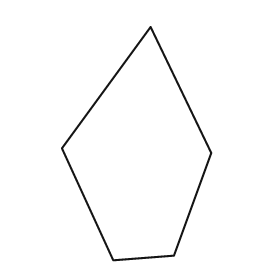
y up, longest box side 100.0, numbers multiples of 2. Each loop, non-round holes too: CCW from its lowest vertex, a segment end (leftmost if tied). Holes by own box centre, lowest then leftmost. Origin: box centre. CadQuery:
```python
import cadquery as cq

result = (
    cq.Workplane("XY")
    .moveTo(-10.0, -50.0)
    .lineTo(16.0, -48.0)
    .lineTo(32.0, -4.0)
    .lineTo(6.0, 50.0)
    .lineTo(-32.0, -2.0)
    .close()
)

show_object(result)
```